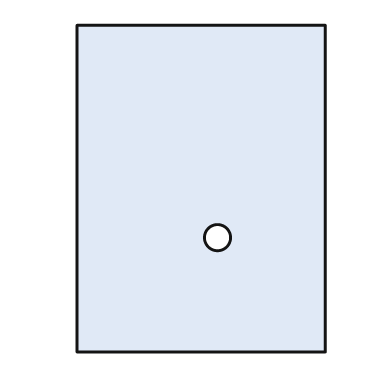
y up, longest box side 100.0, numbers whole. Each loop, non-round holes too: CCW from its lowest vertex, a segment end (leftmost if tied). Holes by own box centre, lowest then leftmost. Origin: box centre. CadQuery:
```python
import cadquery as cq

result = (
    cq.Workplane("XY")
    .moveTo(-38.0, -50.0)
    .lineTo(38.0, -50.0)
    .lineTo(38.0, 50.0)
    .lineTo(-38.0, 50.0)
    .close()
    .moveTo(5.0, -15.0)
    .circle(4.0)
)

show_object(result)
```